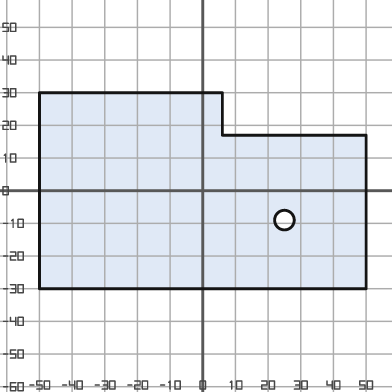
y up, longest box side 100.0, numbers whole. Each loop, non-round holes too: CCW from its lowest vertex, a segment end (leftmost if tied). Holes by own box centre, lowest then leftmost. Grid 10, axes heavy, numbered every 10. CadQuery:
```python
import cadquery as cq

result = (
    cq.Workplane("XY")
    .moveTo(-50.0, -30.0)
    .lineTo(50.0, -30.0)
    .lineTo(50.0, 17.0)
    .lineTo(6.0, 17.0)
    .lineTo(6.0, 30.0)
    .lineTo(-50.0, 30.0)
    .close()
    .moveTo(25.0, -9.0)
    .circle(3.0)
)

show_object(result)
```